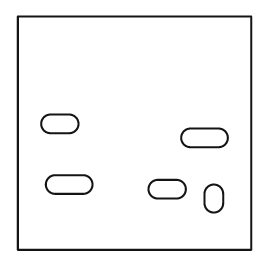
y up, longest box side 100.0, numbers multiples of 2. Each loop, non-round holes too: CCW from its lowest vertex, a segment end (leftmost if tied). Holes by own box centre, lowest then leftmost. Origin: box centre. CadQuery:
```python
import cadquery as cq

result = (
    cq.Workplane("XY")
    .moveTo(-50.0, -50.0)
    .lineTo(50.0, -50.0)
    .lineTo(50.0, 50.0)
    .lineTo(-50.0, 50.0)
    .close()
    .moveTo(30.0, -30.0)
    .threePointArc((34.0, -34.0), (38.0, -30.0))
    .lineTo(38.0, -26.0)
    .threePointArc((34.0, -22.0), (30.0, -26.0))
    .close()
    .moveTo(10.0, -28.0)
    .lineTo(18.0, -28.0)
    .threePointArc((22.0, -24.0), (18.0, -20.0))
    .lineTo(10.0, -20.0)
    .threePointArc((6.0, -24.0), (10.0, -28.0))
    .close()
    .moveTo(-34.0, -26.0)
    .lineTo(-22.0, -26.0)
    .threePointArc((-18.0, -22.0), (-22.0, -18.0))
    .lineTo(-34.0, -18.0)
    .threePointArc((-38.0, -22.0), (-34.0, -26.0))
    .close()
    .moveTo(24.0, -6.0)
    .lineTo(36.0, -6.0)
    .threePointArc((40.0, -2.0), (36.0, 2.0))
    .lineTo(24.0, 2.0)
    .threePointArc((20.0, -2.0), (24.0, -6.0))
    .close()
    .moveTo(-36.0, 0.0)
    .lineTo(-28.0, 0.0)
    .threePointArc((-24.0, 4.0), (-28.0, 8.0))
    .lineTo(-36.0, 8.0)
    .threePointArc((-40.0, 4.0), (-36.0, 0.0))
    .close()
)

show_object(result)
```